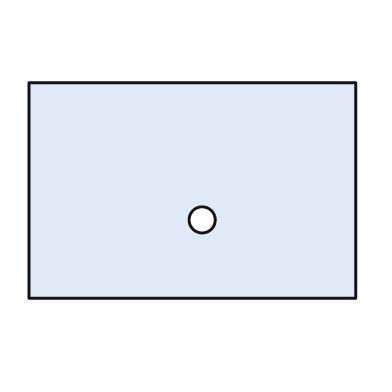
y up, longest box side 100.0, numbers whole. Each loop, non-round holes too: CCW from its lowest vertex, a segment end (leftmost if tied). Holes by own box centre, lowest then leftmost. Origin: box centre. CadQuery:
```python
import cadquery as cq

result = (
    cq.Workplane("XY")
    .moveTo(-50.0, -33.0)
    .lineTo(50.0, -33.0)
    .lineTo(50.0, 33.0)
    .lineTo(-50.0, 33.0)
    .close()
    .moveTo(3.0, -9.0)
    .circle(4.0)
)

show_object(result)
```